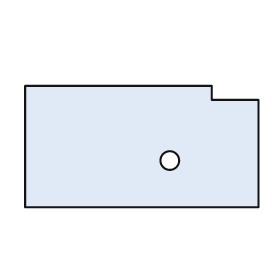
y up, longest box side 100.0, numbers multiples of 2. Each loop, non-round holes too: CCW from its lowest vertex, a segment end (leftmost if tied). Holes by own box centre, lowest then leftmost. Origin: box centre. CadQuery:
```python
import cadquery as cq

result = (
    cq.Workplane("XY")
    .moveTo(-50.0, -26.0)
    .lineTo(50.0, -26.0)
    .lineTo(50.0, 20.0)
    .lineTo(30.0, 20.0)
    .lineTo(30.0, 26.0)
    .lineTo(-50.0, 26.0)
    .close()
    .moveTo(12.0, -6.0)
    .circle(4.0)
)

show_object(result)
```